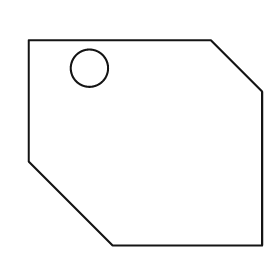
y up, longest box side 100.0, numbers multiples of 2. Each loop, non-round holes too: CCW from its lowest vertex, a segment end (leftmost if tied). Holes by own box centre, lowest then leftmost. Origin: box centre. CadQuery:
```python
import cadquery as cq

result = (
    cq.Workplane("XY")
    .moveTo(-14.0, -44.0)
    .lineTo(50.0, -44.0)
    .lineTo(50.0, 22.0)
    .lineTo(28.0, 44.0)
    .lineTo(-50.0, 44.0)
    .lineTo(-50.0, -8.0)
    .close()
    .moveTo(-24.0, 32.0)
    .circle(8.0)
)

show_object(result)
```